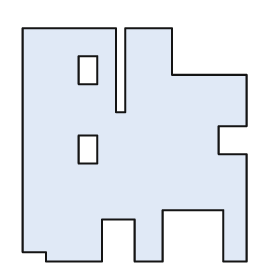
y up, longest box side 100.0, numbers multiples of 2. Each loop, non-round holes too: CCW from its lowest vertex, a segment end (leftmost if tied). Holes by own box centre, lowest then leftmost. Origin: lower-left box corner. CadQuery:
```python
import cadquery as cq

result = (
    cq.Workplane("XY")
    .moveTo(10.0, 0.0)
    .lineTo(34.0, 0.0)
    .lineTo(34.0, 18.0)
    .lineTo(48.0, 18.0)
    .lineTo(48.0, 0.0)
    .lineTo(60.0, 0.0)
    .lineTo(60.0, 22.0)
    .lineTo(86.0, 22.0)
    .lineTo(86.0, 0.0)
    .lineTo(96.0, 0.0)
    .lineTo(96.0, 46.0)
    .lineTo(84.0, 46.0)
    .lineTo(84.0, 58.0)
    .lineTo(96.0, 58.0)
    .lineTo(96.0, 80.0)
    .lineTo(64.0, 80.0)
    .lineTo(64.0, 100.0)
    .lineTo(44.0, 100.0)
    .lineTo(44.0, 64.0)
    .lineTo(40.0, 64.0)
    .lineTo(40.0, 100.0)
    .lineTo(0.0, 100.0)
    .lineTo(0.0, 4.0)
    .lineTo(10.0, 4.0)
    .close()
    .moveTo(24.0, 42.0)
    .lineTo(32.0, 42.0)
    .lineTo(32.0, 54.0)
    .lineTo(24.0, 54.0)
    .close()
    .moveTo(24.0, 76.0)
    .lineTo(32.0, 76.0)
    .lineTo(32.0, 88.0)
    .lineTo(24.0, 88.0)
    .close()
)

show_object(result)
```